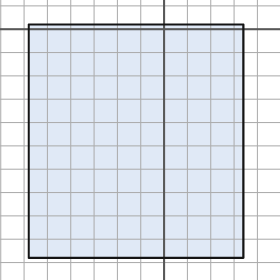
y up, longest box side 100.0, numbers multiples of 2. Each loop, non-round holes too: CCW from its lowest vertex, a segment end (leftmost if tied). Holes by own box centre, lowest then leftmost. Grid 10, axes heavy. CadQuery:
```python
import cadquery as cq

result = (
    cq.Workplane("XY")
    .moveTo(-58.0, -98.0)
    .lineTo(34.0, -98.0)
    .lineTo(34.0, 2.0)
    .lineTo(-58.0, 2.0)
    .close()
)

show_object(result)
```